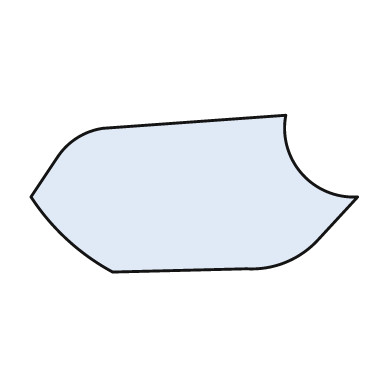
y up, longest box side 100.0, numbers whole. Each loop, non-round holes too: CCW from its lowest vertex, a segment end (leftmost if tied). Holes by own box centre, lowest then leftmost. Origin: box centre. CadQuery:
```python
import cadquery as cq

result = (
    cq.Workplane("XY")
    .moveTo(-25.0, -24.0)
    .lineTo(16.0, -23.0)
    .threePointArc((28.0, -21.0), (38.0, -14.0))
    .lineTo(50.0, -1.0)
    .threePointArc((33.0, 6.0), (28.0, 24.0))
    .lineTo(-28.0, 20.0)
    .threePointArc((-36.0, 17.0), (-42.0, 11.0))
    .lineTo(-50.0, -1.0)
    .threePointArc((-39.0, -14.0), (-25.0, -24.0))
    .close()
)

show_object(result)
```